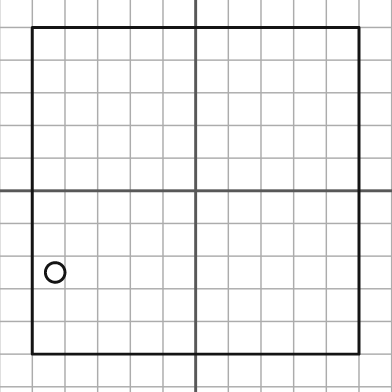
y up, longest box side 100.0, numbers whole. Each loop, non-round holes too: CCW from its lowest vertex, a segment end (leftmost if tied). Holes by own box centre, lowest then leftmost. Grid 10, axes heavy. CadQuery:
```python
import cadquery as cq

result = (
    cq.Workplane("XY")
    .moveTo(-50.0, -50.0)
    .lineTo(50.0, -50.0)
    .lineTo(50.0, 50.0)
    .lineTo(-50.0, 50.0)
    .close()
    .moveTo(-43.0, -25.0)
    .circle(3.0)
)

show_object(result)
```